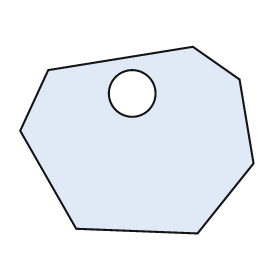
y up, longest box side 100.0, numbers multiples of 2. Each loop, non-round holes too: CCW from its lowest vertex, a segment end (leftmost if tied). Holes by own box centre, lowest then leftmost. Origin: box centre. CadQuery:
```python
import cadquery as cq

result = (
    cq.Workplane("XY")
    .moveTo(26.0, -40.0)
    .lineTo(50.0, -10.0)
    .lineTo(44.0, 26.0)
    .lineTo(24.0, 40.0)
    .lineTo(-38.0, 30.0)
    .lineTo(-50.0, 4.0)
    .lineTo(-26.0, -38.0)
    .close()
    .moveTo(-2.0, 20.0)
    .circle(10.0)
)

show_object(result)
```